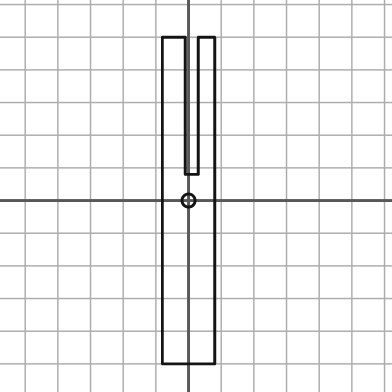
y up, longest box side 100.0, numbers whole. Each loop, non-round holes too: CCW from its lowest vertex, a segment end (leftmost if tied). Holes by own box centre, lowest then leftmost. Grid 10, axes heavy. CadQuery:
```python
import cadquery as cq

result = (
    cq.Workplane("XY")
    .moveTo(-8.0, -50.0)
    .lineTo(8.0, -50.0)
    .lineTo(8.0, 50.0)
    .lineTo(3.0, 50.0)
    .lineTo(3.0, 8.0)
    .lineTo(-1.0, 8.0)
    .lineTo(-1.0, 50.0)
    .lineTo(-8.0, 50.0)
    .close()
    .moveTo(0.0, 0.0)
    .circle(2.0)
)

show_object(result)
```